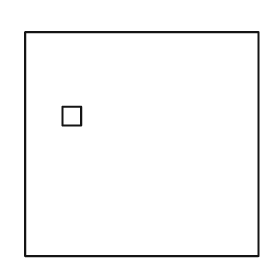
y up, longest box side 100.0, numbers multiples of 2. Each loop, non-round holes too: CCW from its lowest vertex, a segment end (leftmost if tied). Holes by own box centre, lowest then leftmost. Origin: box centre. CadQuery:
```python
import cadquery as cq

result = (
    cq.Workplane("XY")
    .moveTo(-50.0, -48.0)
    .lineTo(50.0, -48.0)
    .lineTo(50.0, 48.0)
    .lineTo(-50.0, 48.0)
    .close()
    .moveTo(-34.0, 8.0)
    .lineTo(-26.0, 8.0)
    .lineTo(-26.0, 16.0)
    .lineTo(-34.0, 16.0)
    .close()
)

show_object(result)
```